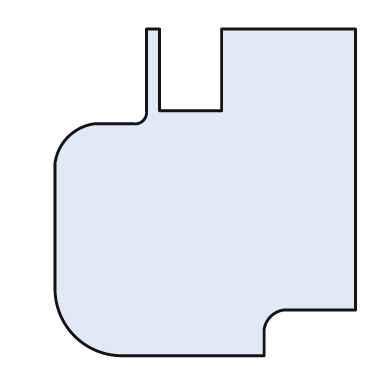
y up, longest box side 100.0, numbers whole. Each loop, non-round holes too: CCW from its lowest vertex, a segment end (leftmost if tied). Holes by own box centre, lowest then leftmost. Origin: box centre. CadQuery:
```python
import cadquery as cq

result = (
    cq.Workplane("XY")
    .moveTo(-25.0, -50.0)
    .lineTo(18.0, -50.0)
    .lineTo(18.0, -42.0)
    .threePointArc((20.0, -38.0), (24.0, -36.0))
    .lineTo(46.0, -36.0)
    .lineTo(46.0, 50.0)
    .lineTo(5.0, 50.0)
    .lineTo(5.0, 25.0)
    .lineTo(-14.0, 25.0)
    .lineTo(-14.0, 50.0)
    .lineTo(-18.0, 50.0)
    .lineTo(-18.0, 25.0)
    .threePointArc((-19.0, 22.0), (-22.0, 21.0))
    .lineTo(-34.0, 21.0)
    .threePointArc((-42.0, 17.0), (-46.0, 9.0))
    .lineTo(-46.0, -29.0)
    .threePointArc((-40.0, -44.0), (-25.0, -50.0))
    .close()
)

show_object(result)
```